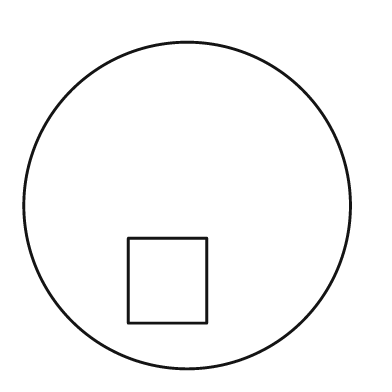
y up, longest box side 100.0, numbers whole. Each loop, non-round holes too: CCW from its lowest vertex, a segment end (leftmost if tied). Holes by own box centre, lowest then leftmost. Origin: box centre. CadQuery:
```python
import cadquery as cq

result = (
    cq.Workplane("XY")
    .moveTo(0.0, 0.0)
    .circle(50.0)
    .moveTo(-18.0, -36.0)
    .lineTo(6.0, -36.0)
    .lineTo(6.0, -10.0)
    .lineTo(-18.0, -10.0)
    .close()
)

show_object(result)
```